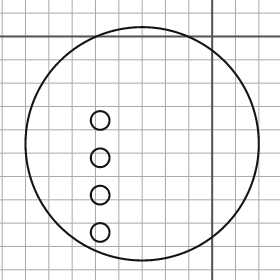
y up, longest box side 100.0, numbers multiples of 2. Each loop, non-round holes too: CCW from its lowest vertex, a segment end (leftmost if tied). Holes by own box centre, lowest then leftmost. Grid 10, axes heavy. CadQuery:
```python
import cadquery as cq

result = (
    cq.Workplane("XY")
    .moveTo(-30.0, -46.0)
    .circle(50.0)
    .moveTo(-48.0, -84.0)
    .circle(4.0)
    .moveTo(-48.0, -68.0)
    .circle(4.0)
    .moveTo(-48.0, -52.0)
    .circle(4.0)
    .moveTo(-48.0, -36.0)
    .circle(4.0)
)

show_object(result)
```